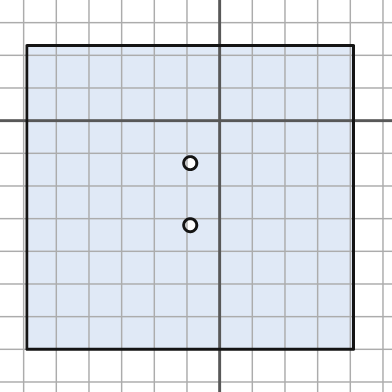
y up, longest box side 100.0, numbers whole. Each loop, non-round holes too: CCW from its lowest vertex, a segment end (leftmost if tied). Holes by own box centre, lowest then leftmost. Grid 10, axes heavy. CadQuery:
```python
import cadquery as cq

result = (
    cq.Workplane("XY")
    .moveTo(-59.0, -70.0)
    .lineTo(41.0, -70.0)
    .lineTo(41.0, 23.0)
    .lineTo(-59.0, 23.0)
    .close()
    .moveTo(-9.0, -32.0)
    .circle(2.0)
    .moveTo(-9.0, -13.0)
    .circle(2.0)
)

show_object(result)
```